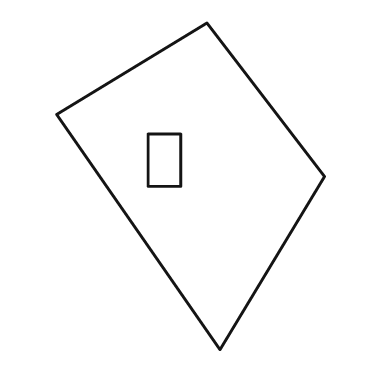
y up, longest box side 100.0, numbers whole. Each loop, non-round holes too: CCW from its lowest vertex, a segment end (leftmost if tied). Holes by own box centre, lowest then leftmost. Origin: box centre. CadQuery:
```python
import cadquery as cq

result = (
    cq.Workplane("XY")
    .moveTo(9.0, -50.0)
    .lineTo(41.0, 3.0)
    .lineTo(5.0, 50.0)
    .lineTo(-41.0, 22.0)
    .close()
    .moveTo(-13.0, 0.0)
    .lineTo(-3.0, 0.0)
    .lineTo(-3.0, 16.0)
    .lineTo(-13.0, 16.0)
    .close()
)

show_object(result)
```